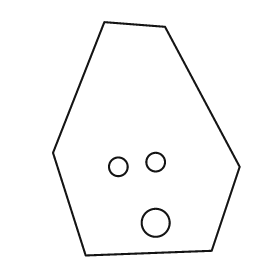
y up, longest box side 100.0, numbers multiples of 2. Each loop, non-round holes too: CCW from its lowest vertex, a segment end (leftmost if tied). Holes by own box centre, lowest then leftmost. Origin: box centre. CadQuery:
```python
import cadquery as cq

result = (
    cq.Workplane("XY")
    .moveTo(-26.0, -50.0)
    .lineTo(28.0, -48.0)
    .lineTo(40.0, -12.0)
    .lineTo(8.0, 48.0)
    .lineTo(-18.0, 50.0)
    .lineTo(-40.0, -6.0)
    .close()
    .moveTo(4.0, -36.0)
    .circle(6.0)
    .moveTo(-12.0, -12.0)
    .circle(4.0)
    .moveTo(4.0, -10.0)
    .circle(4.0)
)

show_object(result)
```